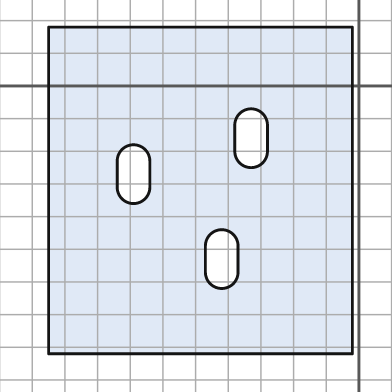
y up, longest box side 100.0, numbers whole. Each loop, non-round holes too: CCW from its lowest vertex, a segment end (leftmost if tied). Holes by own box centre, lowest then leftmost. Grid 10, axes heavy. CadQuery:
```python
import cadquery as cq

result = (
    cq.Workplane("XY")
    .moveTo(-95.0, -82.0)
    .lineTo(-2.0, -82.0)
    .lineTo(-2.0, 18.0)
    .lineTo(-95.0, 18.0)
    .close()
    .moveTo(-47.0, -57.0)
    .threePointArc((-42.0, -62.0), (-37.0, -57.0))
    .lineTo(-37.0, -49.0)
    .threePointArc((-42.0, -44.0), (-47.0, -49.0))
    .close()
    .moveTo(-74.0, -31.0)
    .threePointArc((-69.0, -36.0), (-64.0, -31.0))
    .lineTo(-64.0, -23.0)
    .threePointArc((-69.0, -18.0), (-74.0, -23.0))
    .close()
    .moveTo(-38.0, -20.0)
    .threePointArc((-33.0, -25.0), (-28.0, -20.0))
    .lineTo(-28.0, -12.0)
    .threePointArc((-33.0, -7.0), (-38.0, -12.0))
    .close()
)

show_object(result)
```